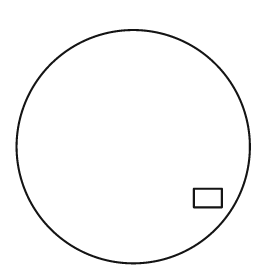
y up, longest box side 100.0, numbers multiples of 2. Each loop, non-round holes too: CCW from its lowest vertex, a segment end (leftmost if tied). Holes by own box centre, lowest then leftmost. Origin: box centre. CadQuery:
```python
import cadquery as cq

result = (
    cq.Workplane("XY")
    .moveTo(0.0, 0.0)
    .circle(50.0)
    .moveTo(26.0, -26.0)
    .lineTo(38.0, -26.0)
    .lineTo(38.0, -18.0)
    .lineTo(26.0, -18.0)
    .close()
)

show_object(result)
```